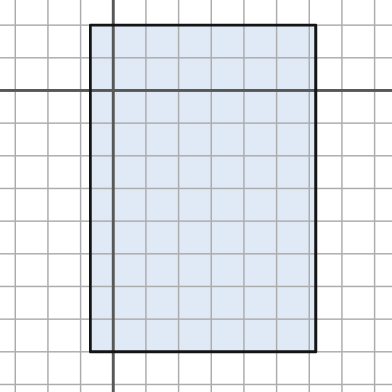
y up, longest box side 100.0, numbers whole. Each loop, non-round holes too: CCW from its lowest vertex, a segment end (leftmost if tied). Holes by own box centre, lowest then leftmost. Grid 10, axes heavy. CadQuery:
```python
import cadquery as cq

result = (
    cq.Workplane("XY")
    .moveTo(-7.0, -80.0)
    .lineTo(62.0, -80.0)
    .lineTo(62.0, 20.0)
    .lineTo(-7.0, 20.0)
    .close()
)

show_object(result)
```